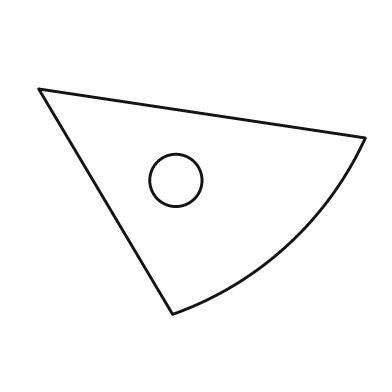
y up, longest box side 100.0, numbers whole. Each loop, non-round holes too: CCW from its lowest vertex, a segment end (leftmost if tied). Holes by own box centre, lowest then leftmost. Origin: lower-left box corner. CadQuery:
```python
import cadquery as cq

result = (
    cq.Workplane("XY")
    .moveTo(41.0, 0.0)
    .threePointArc((76.0, 21.0), (100.0, 54.0))
    .lineTo(0.0, 69.0)
    .close()
    .moveTo(42.0, 41.0)
    .circle(8.0)
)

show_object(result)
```